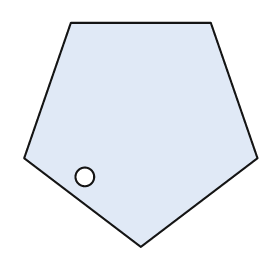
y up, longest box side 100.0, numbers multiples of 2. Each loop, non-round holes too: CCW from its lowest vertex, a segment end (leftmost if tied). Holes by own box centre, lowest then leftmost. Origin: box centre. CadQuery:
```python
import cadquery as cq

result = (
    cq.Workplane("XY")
    .moveTo(0.0, -48.0)
    .lineTo(50.0, -10.0)
    .lineTo(30.0, 48.0)
    .lineTo(-30.0, 48.0)
    .lineTo(-50.0, -10.0)
    .close()
    .moveTo(-24.0, -18.0)
    .circle(4.0)
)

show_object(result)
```